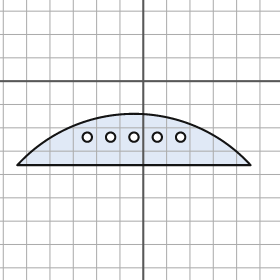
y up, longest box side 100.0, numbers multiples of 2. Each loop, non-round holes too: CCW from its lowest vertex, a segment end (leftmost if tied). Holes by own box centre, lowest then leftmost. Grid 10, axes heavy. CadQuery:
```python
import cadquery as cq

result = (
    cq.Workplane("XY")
    .moveTo(-54.0, -36.0)
    .lineTo(46.0, -36.0)
    .threePointArc((-4.0, -14.0), (-54.0, -36.0))
    .close()
    .moveTo(-24.0, -24.0)
    .circle(2.0)
    .moveTo(-14.0, -24.0)
    .circle(2.0)
    .moveTo(-4.0, -24.0)
    .circle(2.0)
    .moveTo(6.0, -24.0)
    .circle(2.0)
    .moveTo(16.0, -24.0)
    .circle(2.0)
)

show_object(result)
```